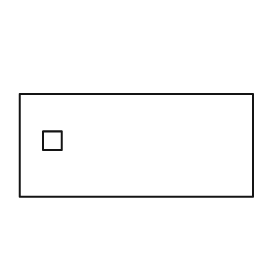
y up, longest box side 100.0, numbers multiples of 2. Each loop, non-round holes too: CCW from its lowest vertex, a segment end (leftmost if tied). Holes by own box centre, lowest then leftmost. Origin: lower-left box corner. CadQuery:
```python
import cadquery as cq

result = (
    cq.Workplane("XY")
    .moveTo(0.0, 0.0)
    .lineTo(100.0, 0.0)
    .lineTo(100.0, 44.0)
    .lineTo(0.0, 44.0)
    .close()
    .moveTo(10.0, 20.0)
    .lineTo(18.0, 20.0)
    .lineTo(18.0, 28.0)
    .lineTo(10.0, 28.0)
    .close()
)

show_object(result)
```